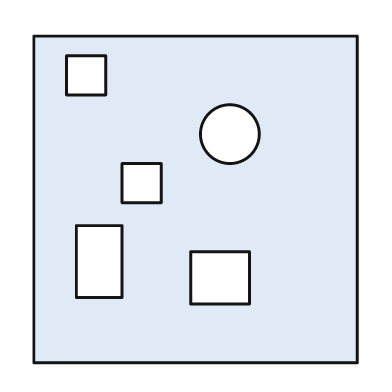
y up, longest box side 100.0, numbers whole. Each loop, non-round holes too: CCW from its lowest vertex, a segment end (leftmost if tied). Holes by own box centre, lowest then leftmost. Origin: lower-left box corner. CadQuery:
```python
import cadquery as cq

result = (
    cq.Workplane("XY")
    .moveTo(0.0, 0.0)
    .lineTo(99.0, 0.0)
    .lineTo(99.0, 100.0)
    .lineTo(0.0, 100.0)
    .close()
    .moveTo(48.0, 18.0)
    .lineTo(66.0, 18.0)
    .lineTo(66.0, 34.0)
    .lineTo(48.0, 34.0)
    .close()
    .moveTo(13.0, 20.0)
    .lineTo(27.0, 20.0)
    .lineTo(27.0, 42.0)
    .lineTo(13.0, 42.0)
    .close()
    .moveTo(27.0, 49.0)
    .lineTo(39.0, 49.0)
    .lineTo(39.0, 61.0)
    .lineTo(27.0, 61.0)
    .close()
    .moveTo(60.0, 70.0)
    .circle(9.0)
    .moveTo(10.0, 82.0)
    .lineTo(22.0, 82.0)
    .lineTo(22.0, 94.0)
    .lineTo(10.0, 94.0)
    .close()
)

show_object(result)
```